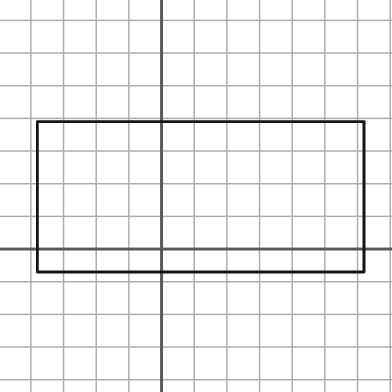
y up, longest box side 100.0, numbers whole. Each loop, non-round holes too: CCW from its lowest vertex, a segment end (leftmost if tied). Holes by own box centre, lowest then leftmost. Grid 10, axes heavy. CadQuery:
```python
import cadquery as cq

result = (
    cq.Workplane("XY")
    .moveTo(-38.0, -7.0)
    .lineTo(62.0, -7.0)
    .lineTo(62.0, 39.0)
    .lineTo(-38.0, 39.0)
    .close()
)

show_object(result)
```